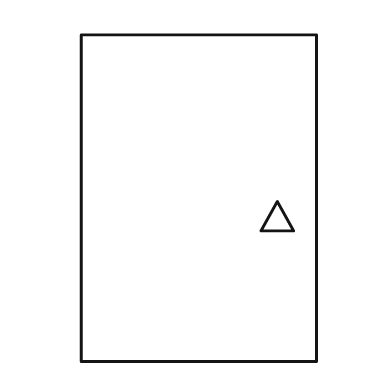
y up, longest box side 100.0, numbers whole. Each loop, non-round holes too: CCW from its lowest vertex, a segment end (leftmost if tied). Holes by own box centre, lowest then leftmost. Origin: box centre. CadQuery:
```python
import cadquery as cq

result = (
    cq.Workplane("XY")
    .moveTo(-36.0, -50.0)
    .lineTo(36.0, -50.0)
    .lineTo(36.0, 50.0)
    .lineTo(-36.0, 50.0)
    .close()
    .moveTo(19.0, -10.0)
    .lineTo(29.0, -10.0)
    .lineTo(24.0, -1.0)
    .close()
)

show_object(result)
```